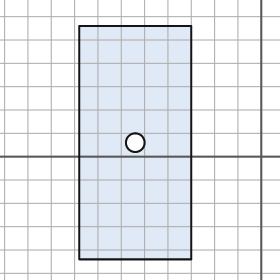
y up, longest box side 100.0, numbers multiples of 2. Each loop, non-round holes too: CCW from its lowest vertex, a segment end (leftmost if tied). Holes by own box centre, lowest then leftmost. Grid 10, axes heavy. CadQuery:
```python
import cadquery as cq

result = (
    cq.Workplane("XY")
    .moveTo(-78.0, -44.0)
    .lineTo(-30.0, -44.0)
    .lineTo(-30.0, 56.0)
    .lineTo(-78.0, 56.0)
    .close()
    .moveTo(-54.0, 6.0)
    .circle(4.0)
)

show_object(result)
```